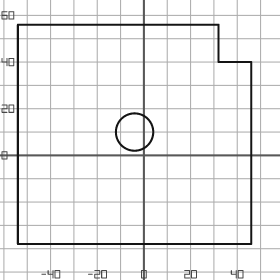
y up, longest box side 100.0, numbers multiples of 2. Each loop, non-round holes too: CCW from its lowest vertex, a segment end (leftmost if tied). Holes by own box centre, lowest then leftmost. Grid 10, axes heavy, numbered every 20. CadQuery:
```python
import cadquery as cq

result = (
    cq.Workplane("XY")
    .moveTo(-54.0, -38.0)
    .lineTo(46.0, -38.0)
    .lineTo(46.0, 40.0)
    .lineTo(32.0, 40.0)
    .lineTo(32.0, 56.0)
    .lineTo(-54.0, 56.0)
    .close()
    .moveTo(-4.0, 10.0)
    .circle(8.0)
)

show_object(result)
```